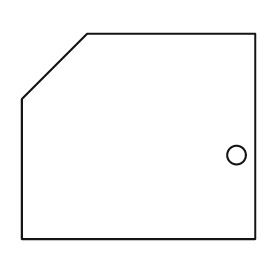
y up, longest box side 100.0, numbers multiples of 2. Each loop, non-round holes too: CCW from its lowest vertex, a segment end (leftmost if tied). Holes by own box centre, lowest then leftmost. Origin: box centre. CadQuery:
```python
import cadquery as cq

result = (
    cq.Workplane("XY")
    .moveTo(-50.0, -44.0)
    .lineTo(50.0, -44.0)
    .lineTo(50.0, 44.0)
    .lineTo(-22.0, 44.0)
    .lineTo(-50.0, 16.0)
    .close()
    .moveTo(42.0, -8.0)
    .circle(4.0)
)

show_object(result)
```